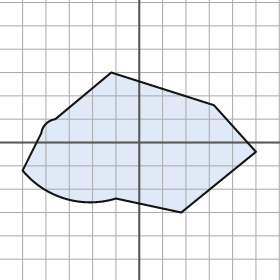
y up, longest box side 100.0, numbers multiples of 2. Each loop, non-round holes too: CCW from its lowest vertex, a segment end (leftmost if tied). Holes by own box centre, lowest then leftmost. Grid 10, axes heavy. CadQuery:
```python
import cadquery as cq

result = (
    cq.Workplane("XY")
    .moveTo(18.0, -30.0)
    .lineTo(50.0, -4.0)
    .lineTo(32.0, 16.0)
    .lineTo(-12.0, 30.0)
    .lineTo(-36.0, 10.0)
    .threePointArc((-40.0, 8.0), (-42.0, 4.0))
    .lineTo(-50.0, -12.0)
    .threePointArc((-32.0, -24.0), (-10.0, -24.0))
    .close()
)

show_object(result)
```